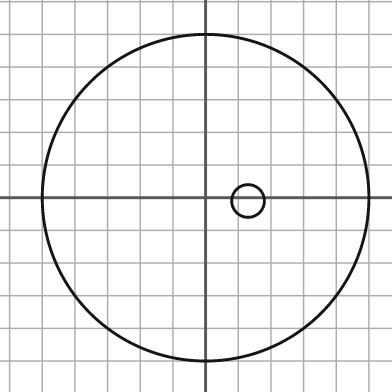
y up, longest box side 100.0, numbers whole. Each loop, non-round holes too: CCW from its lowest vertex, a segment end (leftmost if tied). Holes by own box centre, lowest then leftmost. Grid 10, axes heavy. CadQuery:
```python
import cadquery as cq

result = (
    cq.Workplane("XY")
    .moveTo(0.0, 0.0)
    .circle(50.0)
    .moveTo(13.0, -1.0)
    .circle(5.0)
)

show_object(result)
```